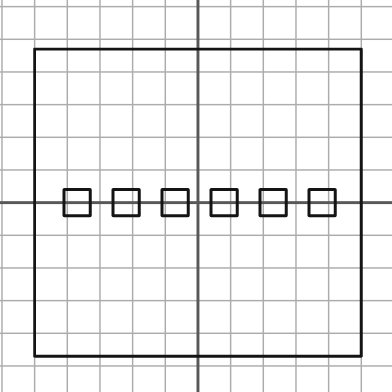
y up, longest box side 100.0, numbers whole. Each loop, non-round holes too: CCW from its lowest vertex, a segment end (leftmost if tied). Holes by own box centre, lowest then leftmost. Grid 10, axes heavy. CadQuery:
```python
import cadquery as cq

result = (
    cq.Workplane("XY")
    .moveTo(-50.0, -47.0)
    .lineTo(50.0, -47.0)
    .lineTo(50.0, 47.0)
    .lineTo(-50.0, 47.0)
    .close()
    .moveTo(-41.0, -4.0)
    .lineTo(-33.0, -4.0)
    .lineTo(-33.0, 4.0)
    .lineTo(-41.0, 4.0)
    .close()
    .moveTo(-26.0, -4.0)
    .lineTo(-18.0, -4.0)
    .lineTo(-18.0, 4.0)
    .lineTo(-26.0, 4.0)
    .close()
    .moveTo(-11.0, -4.0)
    .lineTo(-3.0, -4.0)
    .lineTo(-3.0, 4.0)
    .lineTo(-11.0, 4.0)
    .close()
    .moveTo(4.0, -4.0)
    .lineTo(12.0, -4.0)
    .lineTo(12.0, 4.0)
    .lineTo(4.0, 4.0)
    .close()
    .moveTo(19.0, -4.0)
    .lineTo(27.0, -4.0)
    .lineTo(27.0, 4.0)
    .lineTo(19.0, 4.0)
    .close()
    .moveTo(34.0, -4.0)
    .lineTo(42.0, -4.0)
    .lineTo(42.0, 4.0)
    .lineTo(34.0, 4.0)
    .close()
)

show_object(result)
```